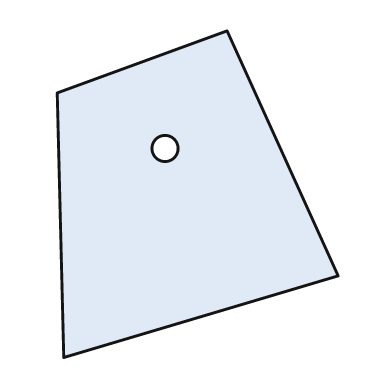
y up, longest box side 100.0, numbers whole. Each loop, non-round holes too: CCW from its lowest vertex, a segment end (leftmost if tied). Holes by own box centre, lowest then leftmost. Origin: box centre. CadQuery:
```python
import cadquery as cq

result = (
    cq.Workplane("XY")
    .moveTo(-41.0, -50.0)
    .lineTo(43.0, -25.0)
    .lineTo(9.0, 50.0)
    .lineTo(-43.0, 31.0)
    .close()
    .moveTo(-10.0, 14.0)
    .circle(4.0)
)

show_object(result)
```